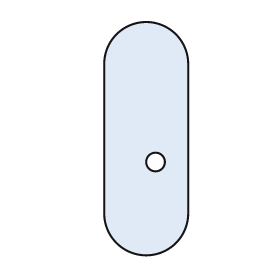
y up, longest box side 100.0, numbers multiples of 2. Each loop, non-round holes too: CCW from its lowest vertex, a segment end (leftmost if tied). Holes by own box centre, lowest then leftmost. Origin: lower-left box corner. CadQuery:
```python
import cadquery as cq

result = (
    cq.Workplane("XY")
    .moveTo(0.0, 18.0)
    .threePointArc((18.0, 0.0), (36.0, 18.0))
    .lineTo(36.0, 82.0)
    .threePointArc((18.0, 100.0), (0.0, 82.0))
    .close()
    .moveTo(22.0, 40.0)
    .circle(4.0)
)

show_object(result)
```